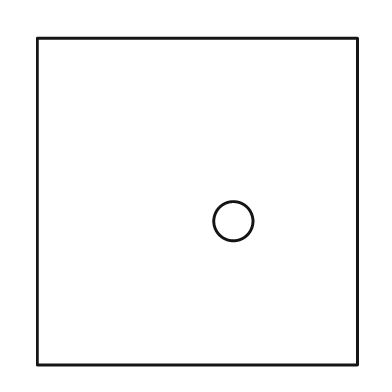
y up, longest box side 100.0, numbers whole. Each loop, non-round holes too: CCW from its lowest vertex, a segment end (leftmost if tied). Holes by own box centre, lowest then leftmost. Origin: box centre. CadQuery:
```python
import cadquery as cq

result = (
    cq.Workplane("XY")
    .moveTo(-49.0, -50.0)
    .lineTo(49.0, -50.0)
    .lineTo(49.0, 50.0)
    .lineTo(-49.0, 50.0)
    .close()
    .moveTo(11.0, -6.0)
    .circle(6.0)
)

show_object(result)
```